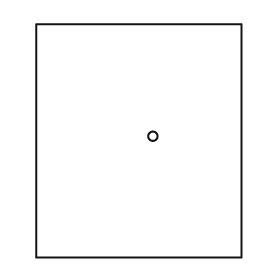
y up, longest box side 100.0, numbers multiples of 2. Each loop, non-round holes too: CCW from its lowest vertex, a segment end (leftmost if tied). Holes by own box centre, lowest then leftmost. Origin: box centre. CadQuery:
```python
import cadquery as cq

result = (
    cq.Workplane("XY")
    .moveTo(-44.0, -50.0)
    .lineTo(44.0, -50.0)
    .lineTo(44.0, 50.0)
    .lineTo(-44.0, 50.0)
    .close()
    .moveTo(6.0, 2.0)
    .circle(2.0)
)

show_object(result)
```